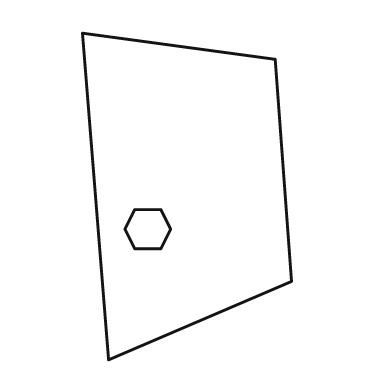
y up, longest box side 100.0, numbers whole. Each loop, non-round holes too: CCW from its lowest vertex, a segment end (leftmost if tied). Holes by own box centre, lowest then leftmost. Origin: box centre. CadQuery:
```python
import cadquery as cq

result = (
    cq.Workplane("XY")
    .moveTo(-24.0, -50.0)
    .lineTo(32.0, -26.0)
    .lineTo(27.0, 42.0)
    .lineTo(-32.0, 50.0)
    .close()
    .moveTo(-16.0, -16.0)
    .lineTo(-8.0, -16.0)
    .lineTo(-5.0, -10.0)
    .lineTo(-8.0, -4.0)
    .lineTo(-16.0, -4.0)
    .lineTo(-19.0, -10.0)
    .close()
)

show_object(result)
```